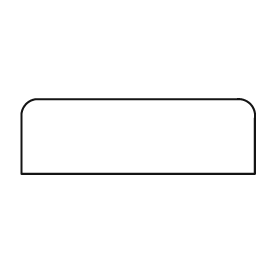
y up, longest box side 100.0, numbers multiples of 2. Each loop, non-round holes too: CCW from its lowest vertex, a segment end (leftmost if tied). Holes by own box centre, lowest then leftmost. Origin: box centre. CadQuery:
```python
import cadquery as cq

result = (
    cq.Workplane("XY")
    .moveTo(-50.0, -16.0)
    .lineTo(50.0, -16.0)
    .lineTo(50.0, 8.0)
    .threePointArc((48.0, 14.0), (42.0, 16.0))
    .lineTo(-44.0, 16.0)
    .threePointArc((-48.0, 14.0), (-50.0, 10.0))
    .close()
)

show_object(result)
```